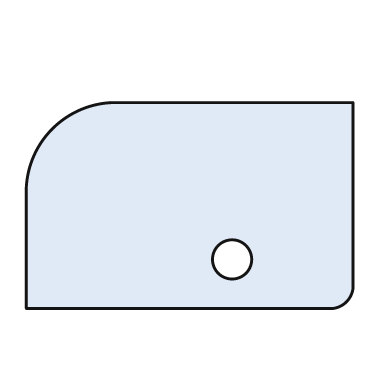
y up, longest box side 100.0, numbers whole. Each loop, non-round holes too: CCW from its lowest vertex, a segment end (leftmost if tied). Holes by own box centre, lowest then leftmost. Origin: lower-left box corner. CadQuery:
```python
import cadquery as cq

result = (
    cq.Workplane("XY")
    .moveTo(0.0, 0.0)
    .lineTo(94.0, 0.0)
    .threePointArc((98.0, 2.0), (100.0, 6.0))
    .lineTo(100.0, 63.0)
    .lineTo(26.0, 63.0)
    .threePointArc((8.0, 55.0), (0.0, 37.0))
    .close()
    .moveTo(63.0, 15.0)
    .circle(6.0)
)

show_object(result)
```